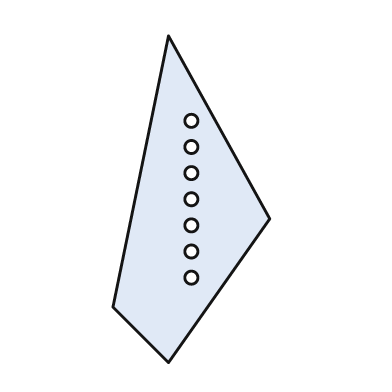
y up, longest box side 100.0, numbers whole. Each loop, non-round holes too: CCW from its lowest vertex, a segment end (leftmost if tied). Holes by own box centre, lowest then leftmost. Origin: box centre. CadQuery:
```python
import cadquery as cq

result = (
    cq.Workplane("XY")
    .moveTo(-7.0, -50.0)
    .lineTo(24.0, -6.0)
    .lineTo(-7.0, 50.0)
    .lineTo(-24.0, -33.0)
    .close()
    .moveTo(0.0, -24.0)
    .circle(2.0)
    .moveTo(0.0, -16.0)
    .circle(2.0)
    .moveTo(0.0, -8.0)
    .circle(2.0)
    .moveTo(0.0, 0.0)
    .circle(2.0)
    .moveTo(0.0, 8.0)
    .circle(2.0)
    .moveTo(0.0, 16.0)
    .circle(2.0)
    .moveTo(0.0, 24.0)
    .circle(2.0)
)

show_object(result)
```